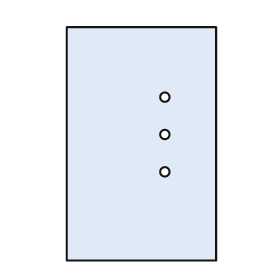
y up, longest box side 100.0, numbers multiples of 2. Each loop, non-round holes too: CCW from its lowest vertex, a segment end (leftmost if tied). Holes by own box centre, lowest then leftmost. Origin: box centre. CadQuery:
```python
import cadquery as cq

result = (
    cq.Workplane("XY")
    .moveTo(-32.0, -50.0)
    .lineTo(32.0, -50.0)
    .lineTo(32.0, 50.0)
    .lineTo(-32.0, 50.0)
    .close()
    .moveTo(10.0, -12.0)
    .circle(2.0)
    .moveTo(10.0, 4.0)
    .circle(2.0)
    .moveTo(10.0, 20.0)
    .circle(2.0)
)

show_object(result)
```